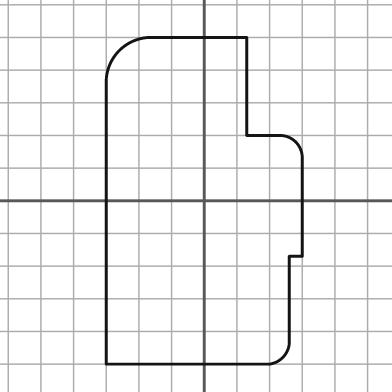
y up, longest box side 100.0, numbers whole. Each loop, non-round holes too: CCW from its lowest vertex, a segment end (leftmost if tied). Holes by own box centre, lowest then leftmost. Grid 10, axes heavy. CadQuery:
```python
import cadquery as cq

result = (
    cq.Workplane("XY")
    .moveTo(-30.0, -50.0)
    .lineTo(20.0, -50.0)
    .threePointArc((24.0, -48.0), (26.0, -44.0))
    .lineTo(26.0, -17.0)
    .lineTo(30.0, -17.0)
    .lineTo(30.0, 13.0)
    .threePointArc((28.0, 18.0), (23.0, 20.0))
    .lineTo(13.0, 20.0)
    .lineTo(13.0, 50.0)
    .lineTo(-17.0, 50.0)
    .threePointArc((-26.0, 46.0), (-30.0, 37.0))
    .close()
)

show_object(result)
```